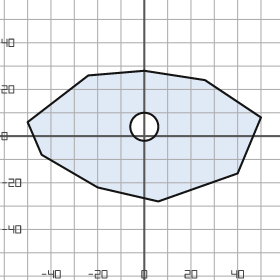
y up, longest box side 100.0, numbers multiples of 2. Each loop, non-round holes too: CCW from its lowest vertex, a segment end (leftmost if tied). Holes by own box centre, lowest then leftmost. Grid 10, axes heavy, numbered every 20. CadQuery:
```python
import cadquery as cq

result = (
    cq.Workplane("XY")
    .moveTo(6.0, -28.0)
    .lineTo(40.0, -16.0)
    .lineTo(50.0, 8.0)
    .lineTo(26.0, 24.0)
    .lineTo(0.0, 28.0)
    .lineTo(-24.0, 26.0)
    .lineTo(-50.0, 6.0)
    .lineTo(-44.0, -8.0)
    .lineTo(-20.0, -22.0)
    .close()
    .moveTo(0.0, 4.0)
    .circle(6.0)
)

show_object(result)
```